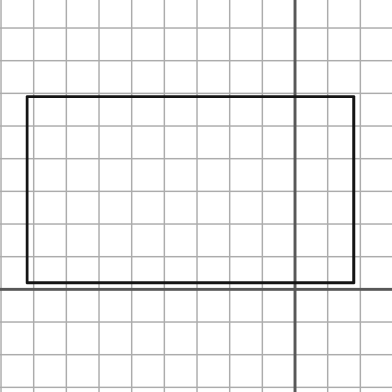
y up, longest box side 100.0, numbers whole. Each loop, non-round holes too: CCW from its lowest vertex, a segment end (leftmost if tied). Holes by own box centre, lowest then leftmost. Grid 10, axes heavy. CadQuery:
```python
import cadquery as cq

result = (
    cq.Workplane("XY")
    .moveTo(-82.0, 2.0)
    .lineTo(18.0, 2.0)
    .lineTo(18.0, 59.0)
    .lineTo(-82.0, 59.0)
    .close()
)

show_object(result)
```